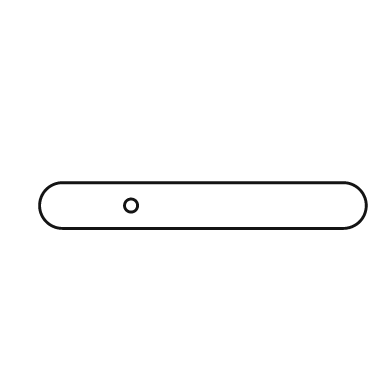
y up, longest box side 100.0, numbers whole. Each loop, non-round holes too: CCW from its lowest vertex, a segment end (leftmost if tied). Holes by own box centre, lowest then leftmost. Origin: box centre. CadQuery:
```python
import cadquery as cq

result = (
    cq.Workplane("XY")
    .moveTo(-43.0, -7.0)
    .lineTo(43.0, -7.0)
    .threePointArc((50.0, 0.0), (43.0, 7.0))
    .lineTo(-43.0, 7.0)
    .threePointArc((-50.0, 0.0), (-43.0, -7.0))
    .close()
    .moveTo(-22.0, 0.0)
    .circle(2.0)
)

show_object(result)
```